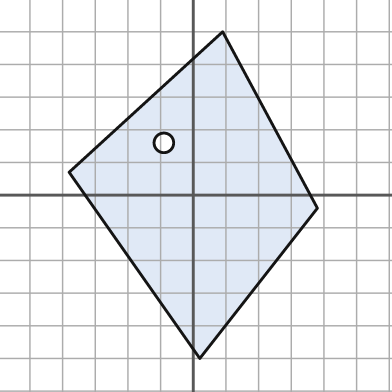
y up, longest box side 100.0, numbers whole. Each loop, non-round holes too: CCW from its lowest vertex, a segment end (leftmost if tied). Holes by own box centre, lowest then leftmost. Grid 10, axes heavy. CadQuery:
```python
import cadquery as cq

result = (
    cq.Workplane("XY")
    .moveTo(2.0, -50.0)
    .lineTo(38.0, -4.0)
    .lineTo(9.0, 50.0)
    .lineTo(-38.0, 7.0)
    .close()
    .moveTo(-9.0, 16.0)
    .circle(3.0)
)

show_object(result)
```